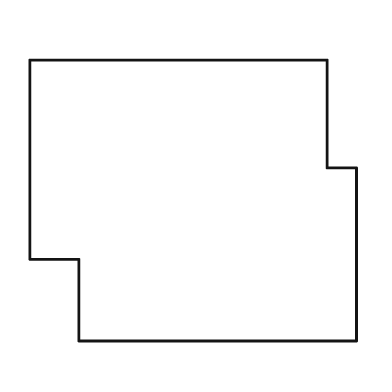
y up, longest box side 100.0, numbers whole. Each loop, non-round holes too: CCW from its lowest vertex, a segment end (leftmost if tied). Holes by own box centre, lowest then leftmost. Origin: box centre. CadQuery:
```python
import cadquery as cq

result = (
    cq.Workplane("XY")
    .moveTo(-35.0, -43.0)
    .lineTo(50.0, -43.0)
    .lineTo(50.0, 10.0)
    .lineTo(41.0, 10.0)
    .lineTo(41.0, 43.0)
    .lineTo(-50.0, 43.0)
    .lineTo(-50.0, -18.0)
    .lineTo(-35.0, -18.0)
    .close()
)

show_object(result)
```